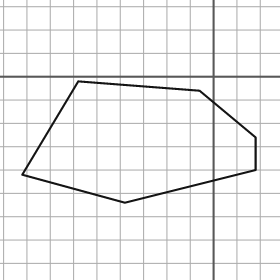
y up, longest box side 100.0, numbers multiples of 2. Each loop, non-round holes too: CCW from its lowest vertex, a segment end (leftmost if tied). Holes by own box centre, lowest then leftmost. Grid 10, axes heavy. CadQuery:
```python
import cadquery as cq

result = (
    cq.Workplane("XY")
    .moveTo(-38.0, -54.0)
    .lineTo(18.0, -40.0)
    .lineTo(18.0, -26.0)
    .lineTo(-6.0, -6.0)
    .lineTo(-58.0, -2.0)
    .lineTo(-82.0, -42.0)
    .close()
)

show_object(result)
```